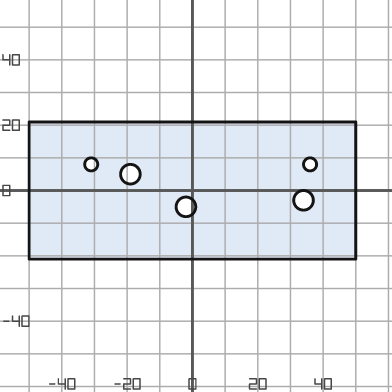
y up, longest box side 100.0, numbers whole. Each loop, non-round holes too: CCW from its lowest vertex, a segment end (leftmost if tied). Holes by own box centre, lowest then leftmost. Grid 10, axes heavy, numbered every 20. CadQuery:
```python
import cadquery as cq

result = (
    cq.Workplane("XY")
    .moveTo(-50.0, -21.0)
    .lineTo(50.0, -21.0)
    .lineTo(50.0, 21.0)
    .lineTo(-50.0, 21.0)
    .close()
    .moveTo(-2.0, -5.0)
    .circle(3.0)
    .moveTo(34.0, -3.0)
    .circle(3.0)
    .moveTo(-19.0, 5.0)
    .circle(3.0)
    .moveTo(-31.0, 8.0)
    .circle(2.0)
    .moveTo(36.0, 8.0)
    .circle(2.0)
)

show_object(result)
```